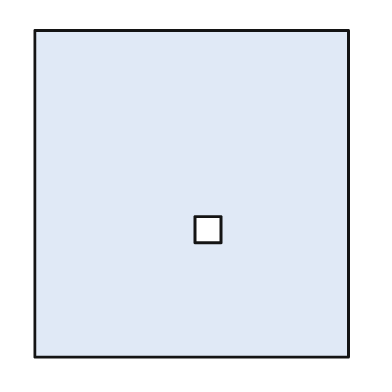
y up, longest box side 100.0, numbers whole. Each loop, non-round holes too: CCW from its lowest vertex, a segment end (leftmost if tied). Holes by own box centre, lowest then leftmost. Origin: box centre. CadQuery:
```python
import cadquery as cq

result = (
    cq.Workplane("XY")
    .moveTo(-48.0, -50.0)
    .lineTo(48.0, -50.0)
    .lineTo(48.0, 50.0)
    .lineTo(-48.0, 50.0)
    .close()
    .moveTo(1.0, -15.0)
    .lineTo(9.0, -15.0)
    .lineTo(9.0, -7.0)
    .lineTo(1.0, -7.0)
    .close()
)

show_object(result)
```